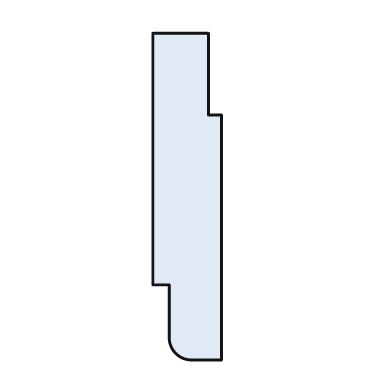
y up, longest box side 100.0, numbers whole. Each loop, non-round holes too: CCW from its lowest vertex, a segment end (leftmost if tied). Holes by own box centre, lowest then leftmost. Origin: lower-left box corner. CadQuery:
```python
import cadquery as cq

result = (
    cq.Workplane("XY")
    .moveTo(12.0, 0.0)
    .lineTo(21.0, 0.0)
    .lineTo(21.0, 75.0)
    .lineTo(17.0, 75.0)
    .lineTo(17.0, 100.0)
    .lineTo(0.0, 100.0)
    .lineTo(0.0, 23.0)
    .lineTo(5.0, 23.0)
    .lineTo(5.0, 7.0)
    .threePointArc((7.0, 2.0), (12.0, 0.0))
    .close()
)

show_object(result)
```